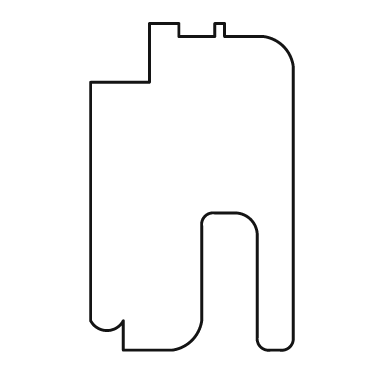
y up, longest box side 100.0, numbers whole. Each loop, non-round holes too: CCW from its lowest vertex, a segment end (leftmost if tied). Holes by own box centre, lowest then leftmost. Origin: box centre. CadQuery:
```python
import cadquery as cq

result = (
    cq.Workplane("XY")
    .moveTo(-21.0, -50.0)
    .lineTo(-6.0, -50.0)
    .threePointArc((0.0, -47.0), (3.0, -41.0))
    .lineTo(3.0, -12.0)
    .threePointArc((4.0, -9.0), (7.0, -8.0))
    .lineTo(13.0, -8.0)
    .threePointArc((18.0, -10.0), (20.0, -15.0))
    .lineTo(20.0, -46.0)
    .threePointArc((21.0, -49.0), (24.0, -50.0))
    .lineTo(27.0, -50.0)
    .threePointArc((30.0, -49.0), (31.0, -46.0))
    .lineTo(31.0, 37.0)
    .threePointArc((28.0, 43.0), (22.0, 46.0))
    .lineTo(10.0, 46.0)
    .lineTo(10.0, 50.0)
    .lineTo(7.0, 50.0)
    .lineTo(7.0, 46.0)
    .lineTo(-4.0, 46.0)
    .lineTo(-4.0, 50.0)
    .lineTo(-13.0, 50.0)
    .lineTo(-13.0, 32.0)
    .lineTo(-31.0, 32.0)
    .lineTo(-31.0, -41.0)
    .threePointArc((-26.0, -44.0), (-21.0, -41.0))
    .close()
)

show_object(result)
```